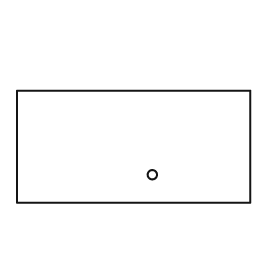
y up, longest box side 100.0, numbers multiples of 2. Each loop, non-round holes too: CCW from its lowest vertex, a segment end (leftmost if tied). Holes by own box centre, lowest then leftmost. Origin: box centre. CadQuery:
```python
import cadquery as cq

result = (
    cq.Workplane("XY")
    .moveTo(-50.0, -24.0)
    .lineTo(50.0, -24.0)
    .lineTo(50.0, 24.0)
    .lineTo(-50.0, 24.0)
    .close()
    .moveTo(8.0, -12.0)
    .circle(2.0)
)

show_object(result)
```